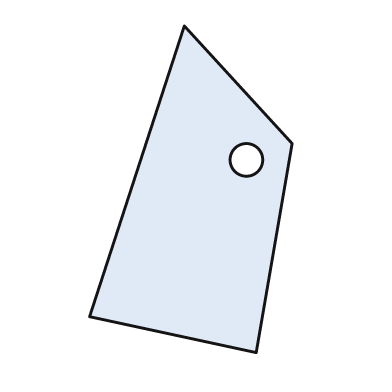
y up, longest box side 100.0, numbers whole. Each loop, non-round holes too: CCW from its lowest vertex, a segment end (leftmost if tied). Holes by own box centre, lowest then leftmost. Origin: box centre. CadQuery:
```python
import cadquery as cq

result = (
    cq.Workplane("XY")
    .moveTo(20.0, -50.0)
    .lineTo(31.0, 14.0)
    .lineTo(-2.0, 50.0)
    .lineTo(-31.0, -39.0)
    .close()
    .moveTo(17.0, 9.0)
    .circle(5.0)
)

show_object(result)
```